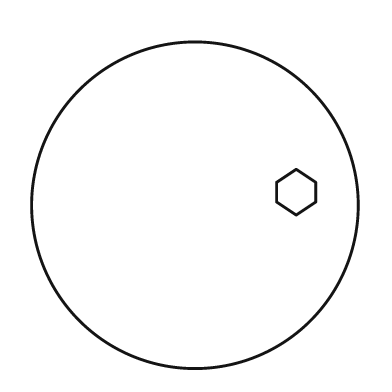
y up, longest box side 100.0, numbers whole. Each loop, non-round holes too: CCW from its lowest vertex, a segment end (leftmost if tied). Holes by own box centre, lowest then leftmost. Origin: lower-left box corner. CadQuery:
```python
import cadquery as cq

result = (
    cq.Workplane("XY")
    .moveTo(50.0, 50.0)
    .circle(50.0)
    .moveTo(81.0, 47.0)
    .lineTo(87.0, 51.0)
    .lineTo(87.0, 57.0)
    .lineTo(81.0, 61.0)
    .lineTo(75.0, 57.0)
    .lineTo(75.0, 51.0)
    .close()
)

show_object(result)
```